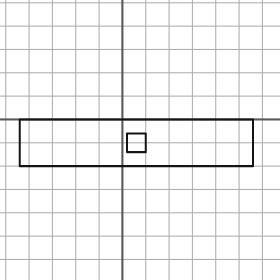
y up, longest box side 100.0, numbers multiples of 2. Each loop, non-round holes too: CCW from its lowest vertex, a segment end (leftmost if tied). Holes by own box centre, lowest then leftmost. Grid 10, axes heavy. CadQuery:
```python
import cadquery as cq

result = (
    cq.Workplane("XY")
    .moveTo(-44.0, -20.0)
    .lineTo(56.0, -20.0)
    .lineTo(56.0, 0.0)
    .lineTo(-44.0, 0.0)
    .close()
    .moveTo(2.0, -14.0)
    .lineTo(10.0, -14.0)
    .lineTo(10.0, -6.0)
    .lineTo(2.0, -6.0)
    .close()
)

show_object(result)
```